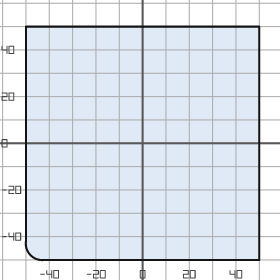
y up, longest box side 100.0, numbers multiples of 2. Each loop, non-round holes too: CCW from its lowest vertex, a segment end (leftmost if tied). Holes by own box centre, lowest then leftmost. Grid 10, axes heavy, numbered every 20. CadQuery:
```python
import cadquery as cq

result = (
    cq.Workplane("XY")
    .moveTo(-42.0, -50.0)
    .lineTo(50.0, -50.0)
    .lineTo(50.0, 50.0)
    .lineTo(-50.0, 50.0)
    .lineTo(-50.0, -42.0)
    .threePointArc((-48.0, -48.0), (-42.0, -50.0))
    .close()
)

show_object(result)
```